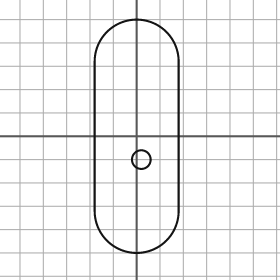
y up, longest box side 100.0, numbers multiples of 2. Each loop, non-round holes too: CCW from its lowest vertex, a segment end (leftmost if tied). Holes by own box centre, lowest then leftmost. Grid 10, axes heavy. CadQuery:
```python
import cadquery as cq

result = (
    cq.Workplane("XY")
    .moveTo(-18.0, -32.0)
    .threePointArc((0.0, -50.0), (18.0, -32.0))
    .lineTo(18.0, 32.0)
    .threePointArc((0.0, 50.0), (-18.0, 32.0))
    .close()
    .moveTo(2.0, -10.0)
    .circle(4.0)
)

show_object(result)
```